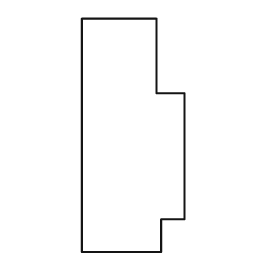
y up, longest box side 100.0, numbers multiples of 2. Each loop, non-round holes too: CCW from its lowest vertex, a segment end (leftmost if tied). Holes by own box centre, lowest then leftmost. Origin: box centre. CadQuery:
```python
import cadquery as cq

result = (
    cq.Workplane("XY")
    .moveTo(-22.0, -50.0)
    .lineTo(12.0, -50.0)
    .lineTo(12.0, -36.0)
    .lineTo(22.0, -36.0)
    .lineTo(22.0, 18.0)
    .lineTo(10.0, 18.0)
    .lineTo(10.0, 50.0)
    .lineTo(-22.0, 50.0)
    .close()
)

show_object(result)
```